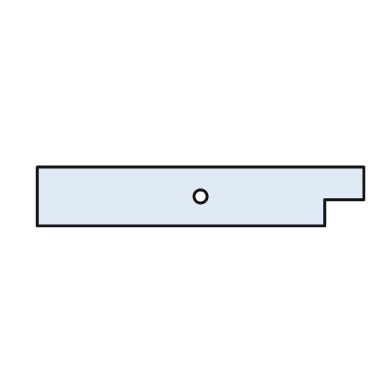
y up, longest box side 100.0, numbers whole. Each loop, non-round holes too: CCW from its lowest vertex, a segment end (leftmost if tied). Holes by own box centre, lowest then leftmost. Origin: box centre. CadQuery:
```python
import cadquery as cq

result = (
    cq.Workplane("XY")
    .moveTo(-50.0, -9.0)
    .lineTo(38.0, -9.0)
    .lineTo(38.0, -1.0)
    .lineTo(50.0, -1.0)
    .lineTo(50.0, 9.0)
    .lineTo(-50.0, 9.0)
    .close()
    .moveTo(0.0, 0.0)
    .circle(2.0)
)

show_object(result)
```